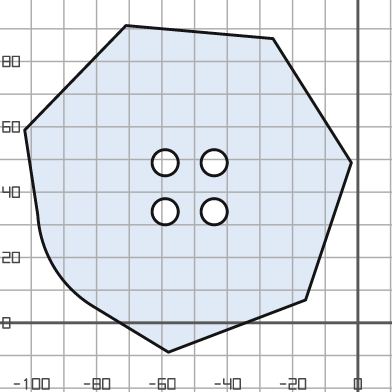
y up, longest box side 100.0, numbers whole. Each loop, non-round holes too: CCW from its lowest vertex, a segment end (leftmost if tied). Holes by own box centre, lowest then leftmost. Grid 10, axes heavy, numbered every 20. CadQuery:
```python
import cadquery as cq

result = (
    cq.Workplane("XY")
    .moveTo(-58.0, -9.0)
    .lineTo(-16.0, 7.0)
    .lineTo(-2.0, 49.0)
    .lineTo(-26.0, 87.0)
    .lineTo(-71.0, 91.0)
    .lineTo(-102.0, 59.0)
    .lineTo(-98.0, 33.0)
    .threePointArc((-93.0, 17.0), (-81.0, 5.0))
    .close()
    .moveTo(-59.0, 34.0)
    .circle(4.0)
    .moveTo(-44.0, 34.0)
    .circle(4.0)
    .moveTo(-59.0, 49.0)
    .circle(4.0)
    .moveTo(-44.0, 49.0)
    .circle(4.0)
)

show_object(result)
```